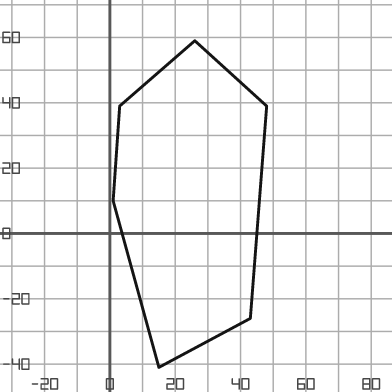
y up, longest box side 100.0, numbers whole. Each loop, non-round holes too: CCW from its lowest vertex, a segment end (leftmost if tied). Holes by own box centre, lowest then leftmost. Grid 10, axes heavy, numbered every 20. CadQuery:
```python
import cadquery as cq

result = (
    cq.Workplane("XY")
    .moveTo(15.0, -41.0)
    .lineTo(43.0, -26.0)
    .lineTo(48.0, 39.0)
    .lineTo(26.0, 59.0)
    .lineTo(3.0, 39.0)
    .lineTo(1.0, 10.0)
    .close()
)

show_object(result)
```